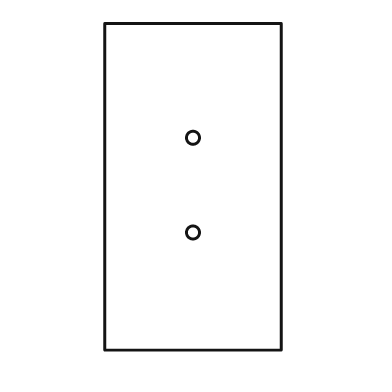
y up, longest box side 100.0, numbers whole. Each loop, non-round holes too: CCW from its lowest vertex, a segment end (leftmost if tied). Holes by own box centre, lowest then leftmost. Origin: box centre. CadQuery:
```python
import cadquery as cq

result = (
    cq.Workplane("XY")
    .moveTo(-27.0, -50.0)
    .lineTo(27.0, -50.0)
    .lineTo(27.0, 50.0)
    .lineTo(-27.0, 50.0)
    .close()
    .moveTo(0.0, -14.0)
    .circle(2.0)
    .moveTo(0.0, 15.0)
    .circle(2.0)
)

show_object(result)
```